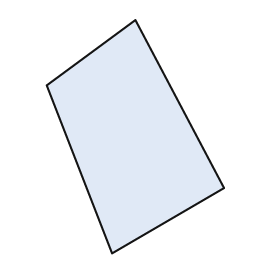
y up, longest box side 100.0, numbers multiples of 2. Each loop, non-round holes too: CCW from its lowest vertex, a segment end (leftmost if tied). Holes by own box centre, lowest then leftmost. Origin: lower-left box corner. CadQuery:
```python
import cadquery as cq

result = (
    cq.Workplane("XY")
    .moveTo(28.0, 0.0)
    .lineTo(76.0, 28.0)
    .lineTo(38.0, 100.0)
    .lineTo(0.0, 72.0)
    .close()
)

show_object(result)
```